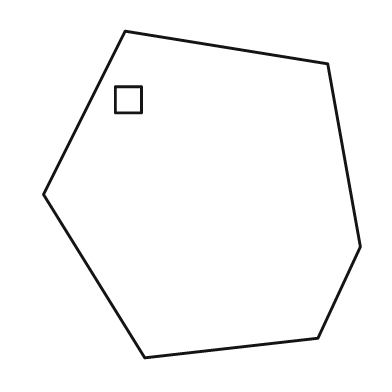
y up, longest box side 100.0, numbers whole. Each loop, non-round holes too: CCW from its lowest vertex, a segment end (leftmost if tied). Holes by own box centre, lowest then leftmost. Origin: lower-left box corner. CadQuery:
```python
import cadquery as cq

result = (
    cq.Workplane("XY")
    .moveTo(31.0, 0.0)
    .lineTo(84.0, 6.0)
    .lineTo(97.0, 34.0)
    .lineTo(87.0, 90.0)
    .lineTo(25.0, 100.0)
    .lineTo(0.0, 50.0)
    .close()
    .moveTo(22.0, 75.0)
    .lineTo(30.0, 75.0)
    .lineTo(30.0, 83.0)
    .lineTo(22.0, 83.0)
    .close()
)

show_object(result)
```